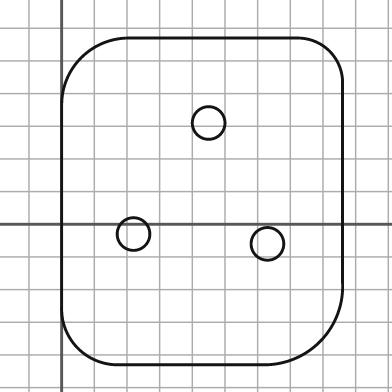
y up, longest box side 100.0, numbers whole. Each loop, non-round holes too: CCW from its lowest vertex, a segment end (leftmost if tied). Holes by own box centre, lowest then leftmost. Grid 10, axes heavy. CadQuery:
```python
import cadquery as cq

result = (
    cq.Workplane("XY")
    .moveTo(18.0, -43.0)
    .lineTo(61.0, -43.0)
    .threePointArc((79.0, -36.0), (86.0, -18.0))
    .lineTo(86.0, 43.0)
    .threePointArc((82.0, 53.0), (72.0, 57.0))
    .lineTo(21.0, 57.0)
    .threePointArc((6.0, 51.0), (0.0, 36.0))
    .lineTo(0.0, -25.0)
    .threePointArc((5.0, -38.0), (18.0, -43.0))
    .close()
    .moveTo(63.0, -6.0)
    .circle(5.0)
    .moveTo(22.0, -3.0)
    .circle(5.0)
    .moveTo(45.0, 31.0)
    .circle(5.0)
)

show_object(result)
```